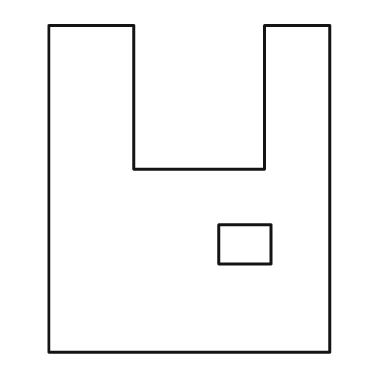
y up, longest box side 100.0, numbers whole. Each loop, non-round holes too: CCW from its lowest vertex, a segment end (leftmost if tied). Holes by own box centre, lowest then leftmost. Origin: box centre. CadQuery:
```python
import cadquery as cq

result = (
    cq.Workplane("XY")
    .moveTo(-43.0, -50.0)
    .lineTo(43.0, -50.0)
    .lineTo(43.0, 50.0)
    .lineTo(23.0, 50.0)
    .lineTo(23.0, 6.0)
    .lineTo(-17.0, 6.0)
    .lineTo(-17.0, 50.0)
    .lineTo(-43.0, 50.0)
    .close()
    .moveTo(9.0, -23.0)
    .lineTo(25.0, -23.0)
    .lineTo(25.0, -11.0)
    .lineTo(9.0, -11.0)
    .close()
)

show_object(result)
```